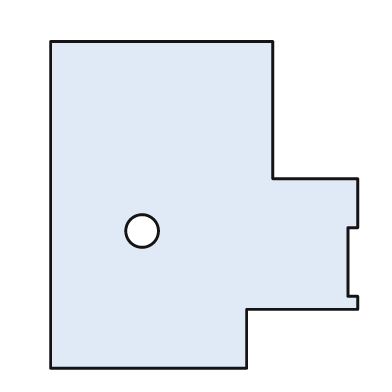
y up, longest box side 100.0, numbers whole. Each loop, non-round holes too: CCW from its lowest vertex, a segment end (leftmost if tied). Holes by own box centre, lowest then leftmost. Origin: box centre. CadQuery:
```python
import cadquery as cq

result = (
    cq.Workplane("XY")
    .moveTo(-47.0, -50.0)
    .lineTo(13.0, -50.0)
    .lineTo(13.0, -32.0)
    .lineTo(47.0, -32.0)
    .lineTo(47.0, -28.0)
    .lineTo(44.0, -28.0)
    .lineTo(44.0, -7.0)
    .lineTo(47.0, -7.0)
    .lineTo(47.0, 8.0)
    .lineTo(21.0, 8.0)
    .lineTo(21.0, 50.0)
    .lineTo(-47.0, 50.0)
    .close()
    .moveTo(-19.0, -8.0)
    .circle(5.0)
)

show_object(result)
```